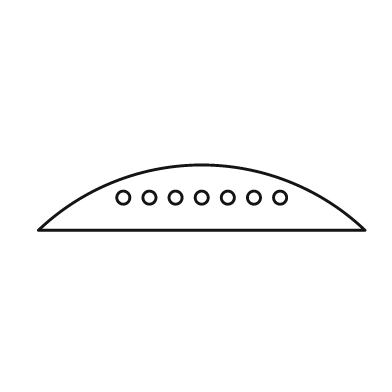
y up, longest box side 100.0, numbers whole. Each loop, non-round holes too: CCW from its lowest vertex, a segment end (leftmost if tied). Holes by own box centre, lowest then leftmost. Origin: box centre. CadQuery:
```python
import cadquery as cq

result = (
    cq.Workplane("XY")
    .moveTo(-50.0, -10.0)
    .lineTo(50.0, -10.0)
    .threePointArc((0.0, 10.0), (-50.0, -10.0))
    .close()
    .moveTo(-24.0, 0.0)
    .circle(2.0)
    .moveTo(-16.0, 0.0)
    .circle(2.0)
    .moveTo(-8.0, 0.0)
    .circle(2.0)
    .moveTo(0.0, 0.0)
    .circle(2.0)
    .moveTo(8.0, 0.0)
    .circle(2.0)
    .moveTo(16.0, 0.0)
    .circle(2.0)
    .moveTo(24.0, 0.0)
    .circle(2.0)
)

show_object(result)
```